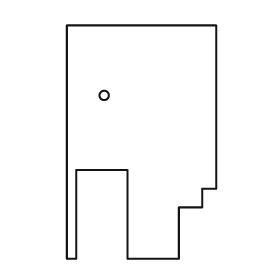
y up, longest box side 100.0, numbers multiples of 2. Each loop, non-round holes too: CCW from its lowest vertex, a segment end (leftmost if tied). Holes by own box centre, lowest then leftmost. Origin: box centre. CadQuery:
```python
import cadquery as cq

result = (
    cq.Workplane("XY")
    .moveTo(-32.0, -50.0)
    .lineTo(-28.0, -50.0)
    .lineTo(-28.0, -12.0)
    .lineTo(-6.0, -12.0)
    .lineTo(-6.0, -50.0)
    .lineTo(16.0, -50.0)
    .lineTo(16.0, -28.0)
    .lineTo(26.0, -28.0)
    .lineTo(26.0, -20.0)
    .lineTo(32.0, -20.0)
    .lineTo(32.0, 50.0)
    .lineTo(-32.0, 50.0)
    .close()
    .moveTo(-16.0, 20.0)
    .circle(2.0)
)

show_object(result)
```